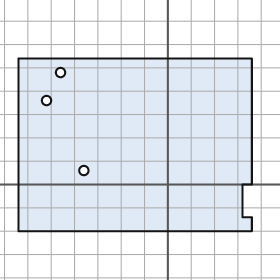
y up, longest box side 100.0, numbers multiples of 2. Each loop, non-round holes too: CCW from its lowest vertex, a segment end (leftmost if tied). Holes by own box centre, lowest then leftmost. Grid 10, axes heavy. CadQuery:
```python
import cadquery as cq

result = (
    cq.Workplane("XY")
    .moveTo(-64.0, -20.0)
    .lineTo(36.0, -20.0)
    .lineTo(36.0, -14.0)
    .lineTo(32.0, -14.0)
    .lineTo(32.0, 0.0)
    .lineTo(36.0, 0.0)
    .lineTo(36.0, 54.0)
    .lineTo(-64.0, 54.0)
    .close()
    .moveTo(-36.0, 6.0)
    .circle(2.0)
    .moveTo(-52.0, 36.0)
    .circle(2.0)
    .moveTo(-46.0, 48.0)
    .circle(2.0)
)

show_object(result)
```